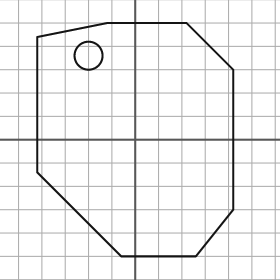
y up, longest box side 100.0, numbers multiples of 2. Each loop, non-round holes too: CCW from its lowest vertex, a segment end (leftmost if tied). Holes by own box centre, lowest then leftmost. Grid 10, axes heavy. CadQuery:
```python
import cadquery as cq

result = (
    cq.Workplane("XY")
    .moveTo(-6.0, -50.0)
    .lineTo(26.0, -50.0)
    .lineTo(42.0, -30.0)
    .lineTo(42.0, 30.0)
    .lineTo(22.0, 50.0)
    .lineTo(-12.0, 50.0)
    .lineTo(-42.0, 44.0)
    .lineTo(-42.0, -14.0)
    .close()
    .moveTo(-20.0, 36.0)
    .circle(6.0)
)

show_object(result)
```